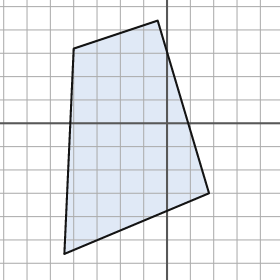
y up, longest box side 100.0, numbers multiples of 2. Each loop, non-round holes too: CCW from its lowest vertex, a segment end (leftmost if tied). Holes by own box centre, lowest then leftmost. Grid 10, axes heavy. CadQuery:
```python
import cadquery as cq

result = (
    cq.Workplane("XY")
    .moveTo(-44.0, -56.0)
    .lineTo(18.0, -30.0)
    .lineTo(-4.0, 44.0)
    .lineTo(-40.0, 32.0)
    .close()
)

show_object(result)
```